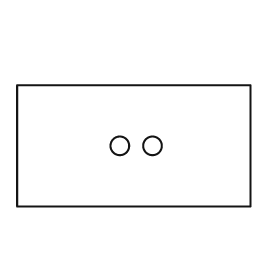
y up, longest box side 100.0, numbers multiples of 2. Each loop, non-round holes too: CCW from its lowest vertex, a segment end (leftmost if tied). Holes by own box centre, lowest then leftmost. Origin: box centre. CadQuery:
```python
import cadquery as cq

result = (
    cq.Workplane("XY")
    .moveTo(-50.0, -26.0)
    .lineTo(50.0, -26.0)
    .lineTo(50.0, 26.0)
    .lineTo(-50.0, 26.0)
    .close()
    .moveTo(-6.0, 0.0)
    .circle(4.0)
    .moveTo(8.0, 0.0)
    .circle(4.0)
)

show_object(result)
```